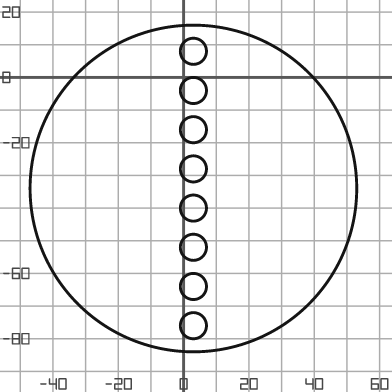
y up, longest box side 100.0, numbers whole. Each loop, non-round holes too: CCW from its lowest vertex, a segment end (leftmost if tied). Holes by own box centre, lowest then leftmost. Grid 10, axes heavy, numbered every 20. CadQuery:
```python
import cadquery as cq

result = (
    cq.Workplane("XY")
    .moveTo(3.0, -34.0)
    .circle(50.0)
    .moveTo(3.0, -76.0)
    .circle(4.0)
    .moveTo(3.0, -64.0)
    .circle(4.0)
    .moveTo(3.0, -52.0)
    .circle(4.0)
    .moveTo(3.0, -40.0)
    .circle(4.0)
    .moveTo(3.0, -28.0)
    .circle(4.0)
    .moveTo(3.0, -16.0)
    .circle(4.0)
    .moveTo(3.0, -4.0)
    .circle(4.0)
    .moveTo(3.0, 8.0)
    .circle(4.0)
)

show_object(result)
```